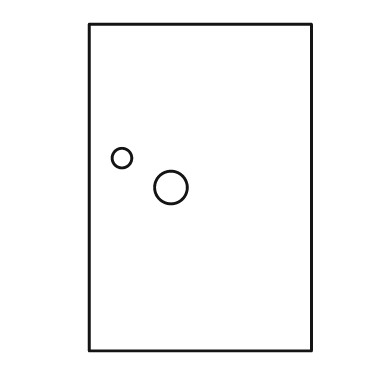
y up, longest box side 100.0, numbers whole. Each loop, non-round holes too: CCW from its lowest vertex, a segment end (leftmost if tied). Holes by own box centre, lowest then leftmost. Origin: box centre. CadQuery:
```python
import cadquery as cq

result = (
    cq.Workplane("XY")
    .moveTo(-34.0, -50.0)
    .lineTo(34.0, -50.0)
    .lineTo(34.0, 50.0)
    .lineTo(-34.0, 50.0)
    .close()
    .moveTo(-9.0, 0.0)
    .circle(5.0)
    .moveTo(-24.0, 9.0)
    .circle(3.0)
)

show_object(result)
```